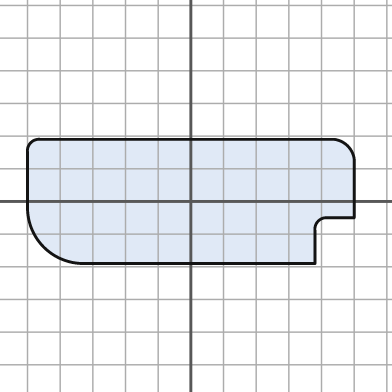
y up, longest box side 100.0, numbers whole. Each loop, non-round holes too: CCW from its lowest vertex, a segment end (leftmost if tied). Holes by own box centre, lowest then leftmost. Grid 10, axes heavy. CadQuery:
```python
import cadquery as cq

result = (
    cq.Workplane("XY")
    .moveTo(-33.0, -19.0)
    .lineTo(38.0, -19.0)
    .lineTo(38.0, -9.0)
    .threePointArc((39.0, -6.0), (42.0, -5.0))
    .lineTo(50.0, -5.0)
    .lineTo(50.0, 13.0)
    .threePointArc((48.0, 17.0), (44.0, 19.0))
    .lineTo(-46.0, 19.0)
    .threePointArc((-49.0, 18.0), (-50.0, 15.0))
    .lineTo(-50.0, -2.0)
    .threePointArc((-45.0, -14.0), (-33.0, -19.0))
    .close()
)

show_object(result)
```